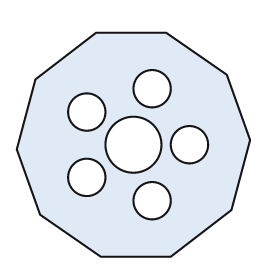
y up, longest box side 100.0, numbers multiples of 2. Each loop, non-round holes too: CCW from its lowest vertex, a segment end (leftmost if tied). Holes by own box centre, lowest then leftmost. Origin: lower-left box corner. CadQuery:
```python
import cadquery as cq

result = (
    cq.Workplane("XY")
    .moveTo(36.0, 0.0)
    .lineTo(66.0, 0.0)
    .lineTo(92.0, 20.0)
    .lineTo(100.0, 50.0)
    .lineTo(90.0, 78.0)
    .lineTo(64.0, 96.0)
    .lineTo(34.0, 96.0)
    .lineTo(8.0, 76.0)
    .lineTo(0.0, 46.0)
    .lineTo(10.0, 18.0)
    .close()
    .moveTo(58.0, 24.0)
    .circle(8.0)
    .moveTo(30.0, 34.0)
    .circle(8.0)
    .moveTo(50.0, 48.0)
    .circle(12.0)
    .moveTo(74.0, 48.0)
    .circle(8.0)
    .moveTo(30.0, 62.0)
    .circle(8.0)
    .moveTo(58.0, 72.0)
    .circle(8.0)
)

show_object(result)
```